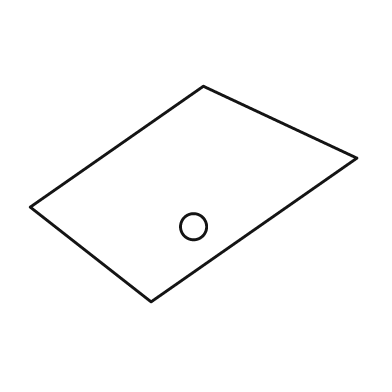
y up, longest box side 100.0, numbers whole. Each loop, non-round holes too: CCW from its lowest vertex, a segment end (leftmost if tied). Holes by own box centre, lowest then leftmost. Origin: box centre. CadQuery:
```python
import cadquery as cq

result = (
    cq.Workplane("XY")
    .moveTo(-13.0, -33.0)
    .lineTo(50.0, 11.0)
    .lineTo(3.0, 33.0)
    .lineTo(-50.0, -4.0)
    .close()
    .moveTo(0.0, -10.0)
    .circle(4.0)
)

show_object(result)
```